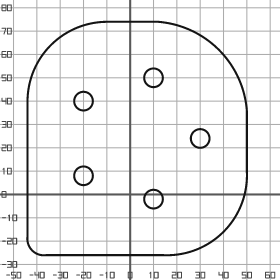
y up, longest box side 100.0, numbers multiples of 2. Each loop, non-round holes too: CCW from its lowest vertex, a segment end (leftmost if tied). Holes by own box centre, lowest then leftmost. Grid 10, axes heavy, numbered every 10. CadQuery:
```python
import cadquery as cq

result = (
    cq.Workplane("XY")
    .moveTo(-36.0, -26.0)
    .lineTo(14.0, -26.0)
    .threePointArc((40.0, -16.0), (50.0, 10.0))
    .lineTo(50.0, 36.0)
    .threePointArc((38.0, 62.0), (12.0, 74.0))
    .lineTo(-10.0, 74.0)
    .threePointArc((-34.0, 64.0), (-44.0, 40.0))
    .lineTo(-44.0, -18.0)
    .threePointArc((-42.0, -24.0), (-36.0, -26.0))
    .close()
    .moveTo(10.0, -2.0)
    .circle(4.0)
    .moveTo(-20.0, 8.0)
    .circle(4.0)
    .moveTo(30.0, 24.0)
    .circle(4.0)
    .moveTo(-20.0, 40.0)
    .circle(4.0)
    .moveTo(10.0, 50.0)
    .circle(4.0)
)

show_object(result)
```